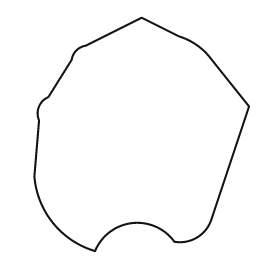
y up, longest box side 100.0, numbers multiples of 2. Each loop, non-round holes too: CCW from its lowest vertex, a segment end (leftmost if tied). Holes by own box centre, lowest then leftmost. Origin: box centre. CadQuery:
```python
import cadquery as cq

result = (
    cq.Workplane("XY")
    .moveTo(-20.0, -50.0)
    .threePointArc((-4.0, -38.0), (14.0, -46.0))
    .threePointArc((24.0, -44.0), (30.0, -36.0))
    .lineTo(46.0, 12.0)
    .lineTo(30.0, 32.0)
    .threePointArc((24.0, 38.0), (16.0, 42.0))
    .lineTo(0.0, 50.0)
    .lineTo(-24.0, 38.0)
    .threePointArc((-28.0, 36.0), (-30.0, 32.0))
    .lineTo(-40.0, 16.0)
    .threePointArc((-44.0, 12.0), (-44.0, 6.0))
    .lineTo(-46.0, -18.0)
    .threePointArc((-38.0, -38.0), (-20.0, -50.0))
    .close()
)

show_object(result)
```